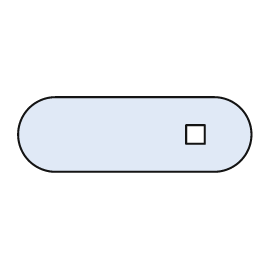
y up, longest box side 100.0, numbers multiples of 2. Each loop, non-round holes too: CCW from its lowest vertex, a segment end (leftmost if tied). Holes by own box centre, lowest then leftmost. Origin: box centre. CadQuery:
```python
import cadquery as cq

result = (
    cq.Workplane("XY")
    .moveTo(-34.0, -16.0)
    .lineTo(34.0, -16.0)
    .threePointArc((50.0, 0.0), (34.0, 16.0))
    .lineTo(-34.0, 16.0)
    .threePointArc((-50.0, 0.0), (-34.0, -16.0))
    .close()
    .moveTo(22.0, -4.0)
    .lineTo(30.0, -4.0)
    .lineTo(30.0, 4.0)
    .lineTo(22.0, 4.0)
    .close()
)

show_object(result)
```